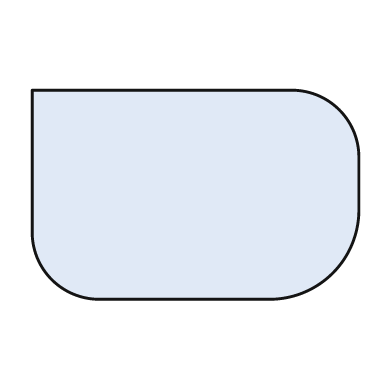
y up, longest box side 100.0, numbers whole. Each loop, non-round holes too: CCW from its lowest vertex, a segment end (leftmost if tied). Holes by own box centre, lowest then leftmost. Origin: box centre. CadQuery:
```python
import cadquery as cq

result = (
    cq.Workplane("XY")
    .moveTo(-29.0, -32.0)
    .lineTo(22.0, -32.0)
    .threePointArc((42.0, -24.0), (50.0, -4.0))
    .lineTo(50.0, 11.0)
    .threePointArc((44.0, 26.0), (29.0, 32.0))
    .lineTo(-50.0, 32.0)
    .lineTo(-50.0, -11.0)
    .threePointArc((-44.0, -26.0), (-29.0, -32.0))
    .close()
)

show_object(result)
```